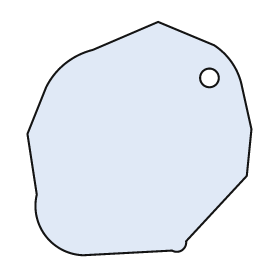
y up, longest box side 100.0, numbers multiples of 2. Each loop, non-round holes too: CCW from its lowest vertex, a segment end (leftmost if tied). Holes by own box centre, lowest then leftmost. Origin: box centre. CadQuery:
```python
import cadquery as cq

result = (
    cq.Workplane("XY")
    .moveTo(-24.0, -50.0)
    .lineTo(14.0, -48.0)
    .threePointArc((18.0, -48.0), (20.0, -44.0))
    .lineTo(46.0, -16.0)
    .lineTo(48.0, 4.0)
    .lineTo(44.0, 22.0)
    .threePointArc((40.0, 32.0), (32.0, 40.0))
    .lineTo(8.0, 50.0)
    .lineTo(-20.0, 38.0)
    .threePointArc((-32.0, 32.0), (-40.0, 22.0))
    .lineTo(-48.0, 2.0)
    .lineTo(-44.0, -24.0)
    .threePointArc((-40.0, -42.0), (-24.0, -50.0))
    .close()
    .moveTo(30.0, 26.0)
    .circle(4.0)
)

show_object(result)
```